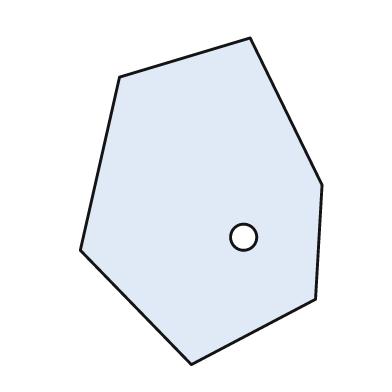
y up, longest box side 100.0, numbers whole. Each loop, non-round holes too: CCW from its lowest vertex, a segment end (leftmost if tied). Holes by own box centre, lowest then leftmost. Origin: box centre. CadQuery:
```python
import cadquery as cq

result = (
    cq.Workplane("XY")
    .moveTo(-3.0, -50.0)
    .lineTo(35.0, -30.0)
    .lineTo(37.0, 5.0)
    .lineTo(15.0, 50.0)
    .lineTo(-25.0, 38.0)
    .lineTo(-37.0, -15.0)
    .close()
    .moveTo(13.0, -11.0)
    .circle(4.0)
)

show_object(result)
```